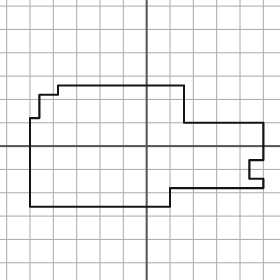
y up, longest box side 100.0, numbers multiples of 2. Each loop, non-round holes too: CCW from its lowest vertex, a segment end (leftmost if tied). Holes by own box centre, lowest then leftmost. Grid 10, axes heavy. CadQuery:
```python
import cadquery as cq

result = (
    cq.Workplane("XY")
    .moveTo(-50.0, -26.0)
    .lineTo(10.0, -26.0)
    .lineTo(10.0, -18.0)
    .lineTo(50.0, -18.0)
    .lineTo(50.0, -14.0)
    .lineTo(44.0, -14.0)
    .lineTo(44.0, -6.0)
    .lineTo(50.0, -6.0)
    .lineTo(50.0, 10.0)
    .lineTo(16.0, 10.0)
    .lineTo(16.0, 26.0)
    .lineTo(-38.0, 26.0)
    .lineTo(-38.0, 22.0)
    .lineTo(-46.0, 22.0)
    .lineTo(-46.0, 12.0)
    .lineTo(-50.0, 12.0)
    .close()
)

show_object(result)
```